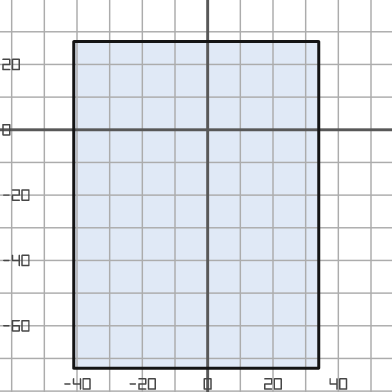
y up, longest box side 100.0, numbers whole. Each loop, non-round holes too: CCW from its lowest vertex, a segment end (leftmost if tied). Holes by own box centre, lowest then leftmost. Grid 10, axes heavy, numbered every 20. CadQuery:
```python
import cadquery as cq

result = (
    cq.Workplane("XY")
    .moveTo(-41.0, -73.0)
    .lineTo(34.0, -73.0)
    .lineTo(34.0, 27.0)
    .lineTo(-41.0, 27.0)
    .close()
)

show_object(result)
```